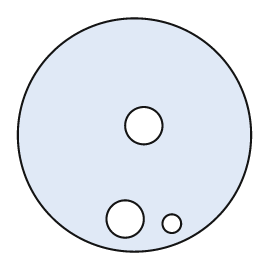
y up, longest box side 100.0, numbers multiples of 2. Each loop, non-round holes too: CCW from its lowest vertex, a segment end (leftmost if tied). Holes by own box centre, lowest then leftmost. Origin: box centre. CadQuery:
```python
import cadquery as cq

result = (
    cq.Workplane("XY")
    .moveTo(0.0, 0.0)
    .circle(50.0)
    .moveTo(16.0, -38.0)
    .circle(4.0)
    .moveTo(-4.0, -36.0)
    .circle(8.0)
    .moveTo(4.0, 4.0)
    .circle(8.0)
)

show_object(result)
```